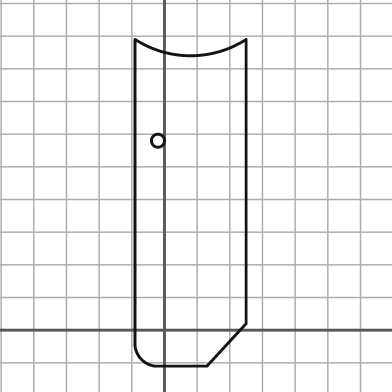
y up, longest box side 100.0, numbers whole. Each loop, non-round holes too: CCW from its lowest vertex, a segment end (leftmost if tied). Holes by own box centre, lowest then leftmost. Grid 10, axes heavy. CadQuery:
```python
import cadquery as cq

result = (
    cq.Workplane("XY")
    .moveTo(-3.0, -11.0)
    .lineTo(13.0, -11.0)
    .lineTo(25.0, 2.0)
    .lineTo(25.0, 89.0)
    .threePointArc((8.0, 84.0), (-9.0, 89.0))
    .lineTo(-9.0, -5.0)
    .threePointArc((-7.0, -9.0), (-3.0, -11.0))
    .close()
    .moveTo(-2.0, 58.0)
    .circle(2.0)
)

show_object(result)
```